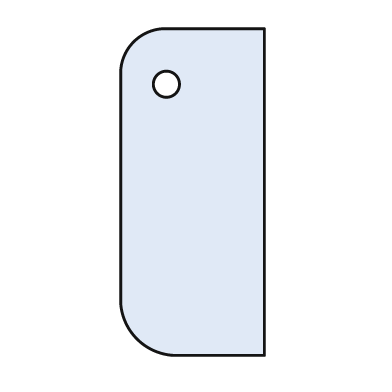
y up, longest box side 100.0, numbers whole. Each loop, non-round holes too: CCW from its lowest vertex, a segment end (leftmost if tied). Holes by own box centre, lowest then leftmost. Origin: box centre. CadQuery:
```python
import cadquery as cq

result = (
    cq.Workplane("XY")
    .moveTo(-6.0, -50.0)
    .lineTo(22.0, -50.0)
    .lineTo(22.0, 50.0)
    .lineTo(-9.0, 50.0)
    .threePointArc((-18.0, 46.0), (-22.0, 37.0))
    .lineTo(-22.0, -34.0)
    .threePointArc((-17.0, -45.0), (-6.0, -50.0))
    .close()
    .moveTo(-8.0, 33.0)
    .circle(4.0)
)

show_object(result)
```